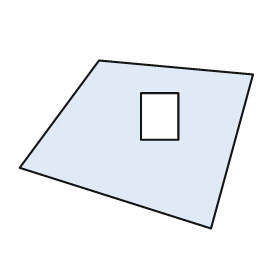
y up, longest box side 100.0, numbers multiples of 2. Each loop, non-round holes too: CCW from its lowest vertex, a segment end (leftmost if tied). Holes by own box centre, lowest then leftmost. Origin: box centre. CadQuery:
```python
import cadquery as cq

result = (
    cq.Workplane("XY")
    .moveTo(32.0, -36.0)
    .lineTo(50.0, 30.0)
    .lineTo(-16.0, 36.0)
    .lineTo(-50.0, -10.0)
    .close()
    .moveTo(2.0, 2.0)
    .lineTo(18.0, 2.0)
    .lineTo(18.0, 22.0)
    .lineTo(2.0, 22.0)
    .close()
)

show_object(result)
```